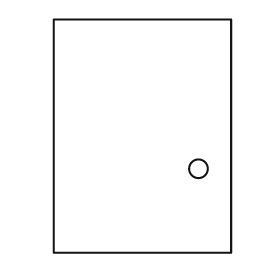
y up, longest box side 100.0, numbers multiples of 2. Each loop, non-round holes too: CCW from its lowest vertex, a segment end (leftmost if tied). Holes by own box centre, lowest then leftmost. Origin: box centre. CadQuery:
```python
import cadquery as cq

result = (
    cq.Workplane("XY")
    .moveTo(-38.0, -50.0)
    .lineTo(38.0, -50.0)
    .lineTo(38.0, 50.0)
    .lineTo(-38.0, 50.0)
    .close()
    .moveTo(24.0, -14.0)
    .circle(4.0)
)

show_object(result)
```